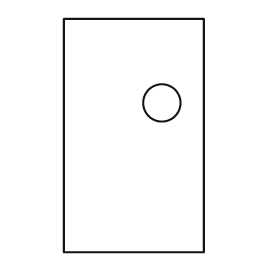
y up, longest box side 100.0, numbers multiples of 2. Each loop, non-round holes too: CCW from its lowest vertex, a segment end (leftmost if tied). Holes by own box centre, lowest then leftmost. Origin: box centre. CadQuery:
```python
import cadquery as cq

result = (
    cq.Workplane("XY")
    .moveTo(-30.0, -50.0)
    .lineTo(30.0, -50.0)
    .lineTo(30.0, 50.0)
    .lineTo(-30.0, 50.0)
    .close()
    .moveTo(12.0, 14.0)
    .circle(8.0)
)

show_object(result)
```